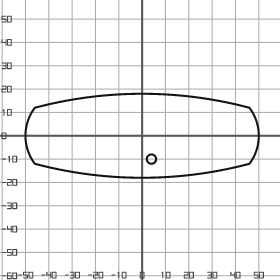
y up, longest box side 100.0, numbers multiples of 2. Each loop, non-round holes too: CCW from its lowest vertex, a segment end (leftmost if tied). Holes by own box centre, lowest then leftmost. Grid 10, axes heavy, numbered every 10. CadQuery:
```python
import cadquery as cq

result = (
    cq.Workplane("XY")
    .moveTo(-46.0, -12.0)
    .threePointArc((0.0, -18.0), (46.0, -12.0))
    .threePointArc((50.0, 0.0), (46.0, 12.0))
    .threePointArc((0.0, 18.0), (-46.0, 12.0))
    .threePointArc((-50.0, 0.0), (-46.0, -12.0))
    .close()
    .moveTo(4.0, -10.0)
    .circle(2.0)
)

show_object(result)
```